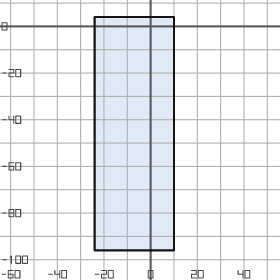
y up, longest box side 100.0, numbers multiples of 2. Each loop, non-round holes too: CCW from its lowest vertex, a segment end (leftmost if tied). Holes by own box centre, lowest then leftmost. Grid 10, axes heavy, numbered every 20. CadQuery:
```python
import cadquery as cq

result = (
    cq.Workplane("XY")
    .moveTo(-24.0, -96.0)
    .lineTo(10.0, -96.0)
    .lineTo(10.0, 4.0)
    .lineTo(-24.0, 4.0)
    .close()
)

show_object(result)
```